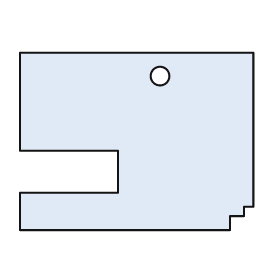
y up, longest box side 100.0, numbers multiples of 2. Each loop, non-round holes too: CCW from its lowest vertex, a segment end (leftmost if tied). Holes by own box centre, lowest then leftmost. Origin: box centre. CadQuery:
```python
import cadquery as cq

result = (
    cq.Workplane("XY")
    .moveTo(-50.0, -38.0)
    .lineTo(40.0, -38.0)
    .lineTo(40.0, -32.0)
    .lineTo(46.0, -32.0)
    .lineTo(46.0, -28.0)
    .lineTo(50.0, -28.0)
    .lineTo(50.0, 38.0)
    .lineTo(-50.0, 38.0)
    .lineTo(-50.0, -4.0)
    .lineTo(-8.0, -4.0)
    .lineTo(-8.0, -22.0)
    .lineTo(-50.0, -22.0)
    .close()
    .moveTo(10.0, 28.0)
    .circle(4.0)
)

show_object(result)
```